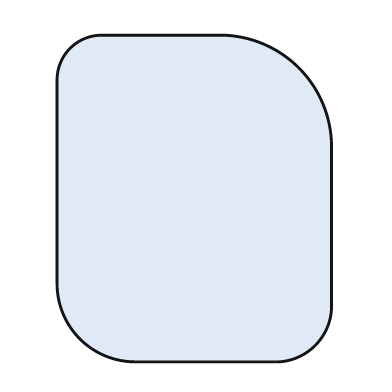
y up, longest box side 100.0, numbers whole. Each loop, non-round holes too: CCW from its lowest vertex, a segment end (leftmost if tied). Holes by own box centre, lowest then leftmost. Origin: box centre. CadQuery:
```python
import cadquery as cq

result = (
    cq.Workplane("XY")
    .moveTo(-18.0, -50.0)
    .lineTo(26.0, -50.0)
    .threePointArc((37.0, -45.0), (42.0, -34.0))
    .lineTo(42.0, 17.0)
    .threePointArc((32.0, 40.0), (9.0, 50.0))
    .lineTo(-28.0, 50.0)
    .threePointArc((-38.0, 46.0), (-42.0, 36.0))
    .lineTo(-42.0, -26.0)
    .threePointArc((-35.0, -43.0), (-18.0, -50.0))
    .close()
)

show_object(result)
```